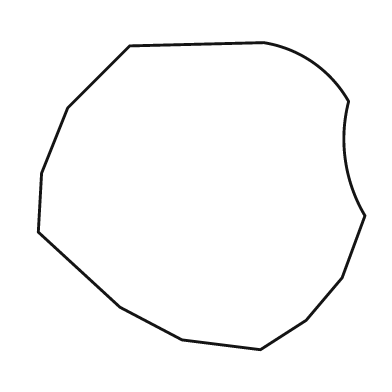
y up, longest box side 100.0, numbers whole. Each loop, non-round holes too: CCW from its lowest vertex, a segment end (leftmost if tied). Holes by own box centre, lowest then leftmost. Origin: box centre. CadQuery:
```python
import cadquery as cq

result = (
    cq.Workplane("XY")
    .moveTo(18.0, -47.0)
    .lineTo(32.0, -38.0)
    .lineTo(43.0, -25.0)
    .lineTo(50.0, -6.0)
    .threePointArc((44.0, 11.0), (45.0, 29.0))
    .threePointArc((34.0, 41.0), (19.0, 47.0))
    .lineTo(-22.0, 46.0)
    .lineTo(-41.0, 27.0)
    .lineTo(-49.0, 7.0)
    .lineTo(-50.0, -11.0)
    .lineTo(-25.0, -34.0)
    .lineTo(-6.0, -44.0)
    .close()
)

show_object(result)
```